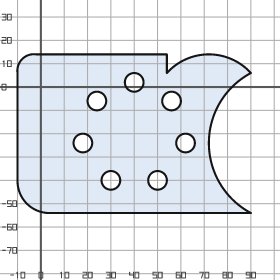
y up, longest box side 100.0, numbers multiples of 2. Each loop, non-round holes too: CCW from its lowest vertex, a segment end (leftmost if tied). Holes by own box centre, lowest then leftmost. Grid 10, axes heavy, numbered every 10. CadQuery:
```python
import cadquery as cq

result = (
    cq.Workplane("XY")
    .moveTo(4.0, -54.0)
    .lineTo(90.0, -54.0)
    .threePointArc((72.0, -24.0), (90.0, 6.0))
    .threePointArc((72.0, 14.0), (54.0, 6.0))
    .lineTo(54.0, 14.0)
    .lineTo(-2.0, 14.0)
    .threePointArc((-8.0, 12.0), (-10.0, 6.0))
    .lineTo(-10.0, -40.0)
    .threePointArc((-6.0, -50.0), (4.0, -54.0))
    .close()
    .moveTo(30.0, -40.0)
    .circle(4.0)
    .moveTo(50.0, -40.0)
    .circle(4.0)
    .moveTo(18.0, -24.0)
    .circle(4.0)
    .moveTo(62.0, -24.0)
    .circle(4.0)
    .moveTo(24.0, -6.0)
    .circle(4.0)
    .moveTo(56.0, -6.0)
    .circle(4.0)
    .moveTo(40.0, 2.0)
    .circle(4.0)
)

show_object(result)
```